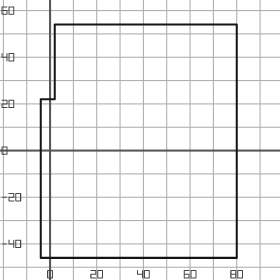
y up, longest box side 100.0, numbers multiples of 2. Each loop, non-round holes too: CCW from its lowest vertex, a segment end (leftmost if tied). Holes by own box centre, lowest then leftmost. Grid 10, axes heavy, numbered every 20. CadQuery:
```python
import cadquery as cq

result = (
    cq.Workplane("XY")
    .moveTo(-4.0, -46.0)
    .lineTo(80.0, -46.0)
    .lineTo(80.0, 54.0)
    .lineTo(2.0, 54.0)
    .lineTo(2.0, 22.0)
    .lineTo(-4.0, 22.0)
    .close()
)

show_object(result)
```